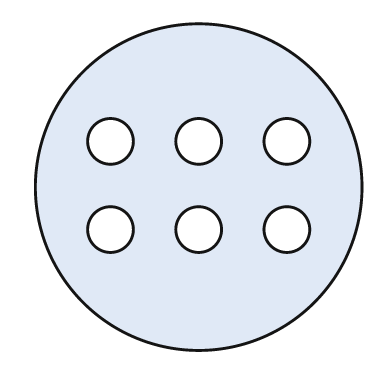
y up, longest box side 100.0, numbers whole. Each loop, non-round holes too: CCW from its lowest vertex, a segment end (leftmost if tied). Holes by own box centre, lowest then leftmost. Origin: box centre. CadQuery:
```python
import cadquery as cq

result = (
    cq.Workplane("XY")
    .moveTo(0.0, 0.0)
    .circle(50.0)
    .moveTo(-27.0, -13.0)
    .circle(7.0)
    .moveTo(0.0, -13.0)
    .circle(7.0)
    .moveTo(27.0, -13.0)
    .circle(7.0)
    .moveTo(-27.0, 14.0)
    .circle(7.0)
    .moveTo(0.0, 14.0)
    .circle(7.0)
    .moveTo(27.0, 14.0)
    .circle(7.0)
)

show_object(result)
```